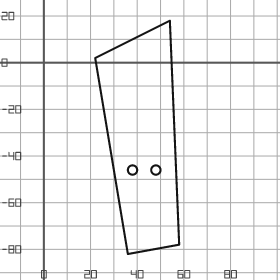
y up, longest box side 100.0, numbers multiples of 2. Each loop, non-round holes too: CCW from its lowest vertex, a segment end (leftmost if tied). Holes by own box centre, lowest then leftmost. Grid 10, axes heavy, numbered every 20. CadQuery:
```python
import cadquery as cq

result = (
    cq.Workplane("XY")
    .moveTo(36.0, -82.0)
    .lineTo(58.0, -78.0)
    .lineTo(54.0, 18.0)
    .lineTo(22.0, 2.0)
    .close()
    .moveTo(38.0, -46.0)
    .circle(2.0)
    .moveTo(48.0, -46.0)
    .circle(2.0)
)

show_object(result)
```